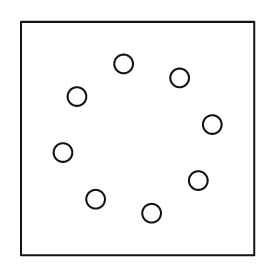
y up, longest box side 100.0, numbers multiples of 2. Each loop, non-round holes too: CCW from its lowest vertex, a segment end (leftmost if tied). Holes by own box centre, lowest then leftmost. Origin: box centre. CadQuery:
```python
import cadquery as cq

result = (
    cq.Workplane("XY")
    .moveTo(-50.0, -50.0)
    .lineTo(50.0, -50.0)
    .lineTo(50.0, 50.0)
    .lineTo(-50.0, 50.0)
    .close()
    .moveTo(6.0, -32.0)
    .circle(4.0)
    .moveTo(-18.0, -26.0)
    .circle(4.0)
    .moveTo(26.0, -18.0)
    .circle(4.0)
    .moveTo(-32.0, -6.0)
    .circle(4.0)
    .moveTo(32.0, 6.0)
    .circle(4.0)
    .moveTo(-26.0, 18.0)
    .circle(4.0)
    .moveTo(18.0, 26.0)
    .circle(4.0)
    .moveTo(-6.0, 32.0)
    .circle(4.0)
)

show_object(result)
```